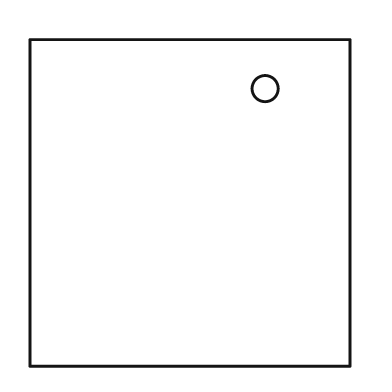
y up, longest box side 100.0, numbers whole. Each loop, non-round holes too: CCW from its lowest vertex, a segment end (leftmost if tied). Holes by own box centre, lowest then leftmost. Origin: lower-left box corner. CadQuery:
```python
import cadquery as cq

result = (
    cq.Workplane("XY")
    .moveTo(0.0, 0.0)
    .lineTo(98.0, 0.0)
    .lineTo(98.0, 100.0)
    .lineTo(0.0, 100.0)
    .close()
    .moveTo(72.0, 85.0)
    .circle(4.0)
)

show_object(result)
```